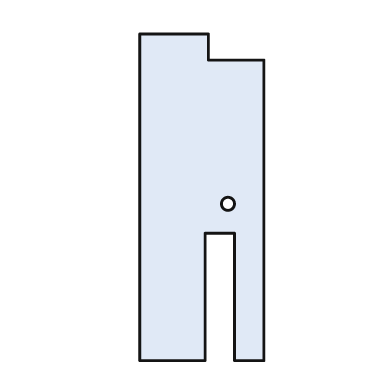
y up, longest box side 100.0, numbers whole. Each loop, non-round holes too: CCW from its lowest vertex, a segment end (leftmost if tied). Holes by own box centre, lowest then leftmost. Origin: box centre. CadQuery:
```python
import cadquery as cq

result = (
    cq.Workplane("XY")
    .moveTo(-19.0, -50.0)
    .lineTo(1.0, -50.0)
    .lineTo(1.0, -11.0)
    .lineTo(10.0, -11.0)
    .lineTo(10.0, -50.0)
    .lineTo(19.0, -50.0)
    .lineTo(19.0, 42.0)
    .lineTo(2.0, 42.0)
    .lineTo(2.0, 50.0)
    .lineTo(-19.0, 50.0)
    .close()
    .moveTo(8.0, -2.0)
    .circle(2.0)
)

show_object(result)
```